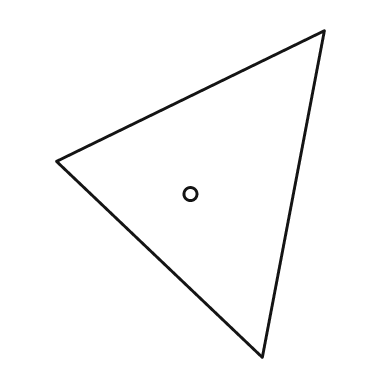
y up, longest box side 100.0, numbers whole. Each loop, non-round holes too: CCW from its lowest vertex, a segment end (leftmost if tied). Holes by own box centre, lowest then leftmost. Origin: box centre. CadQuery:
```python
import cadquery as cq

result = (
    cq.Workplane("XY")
    .moveTo(22.0, -50.0)
    .lineTo(41.0, 50.0)
    .lineTo(-41.0, 10.0)
    .close()
    .moveTo(0.0, 0.0)
    .circle(2.0)
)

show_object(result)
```